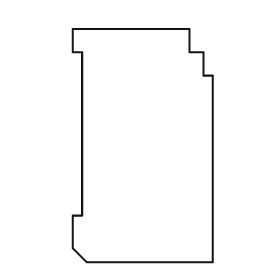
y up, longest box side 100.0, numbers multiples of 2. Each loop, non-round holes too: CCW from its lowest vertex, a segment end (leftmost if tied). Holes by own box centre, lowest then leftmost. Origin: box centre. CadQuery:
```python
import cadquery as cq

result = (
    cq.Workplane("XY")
    .moveTo(-24.0, -50.0)
    .lineTo(30.0, -50.0)
    .lineTo(30.0, 30.0)
    .lineTo(26.0, 30.0)
    .lineTo(26.0, 40.0)
    .lineTo(20.0, 40.0)
    .lineTo(20.0, 50.0)
    .lineTo(-30.0, 50.0)
    .lineTo(-30.0, 40.0)
    .lineTo(-26.0, 40.0)
    .lineTo(-26.0, -30.0)
    .lineTo(-30.0, -30.0)
    .lineTo(-30.0, -44.0)
    .close()
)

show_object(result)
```